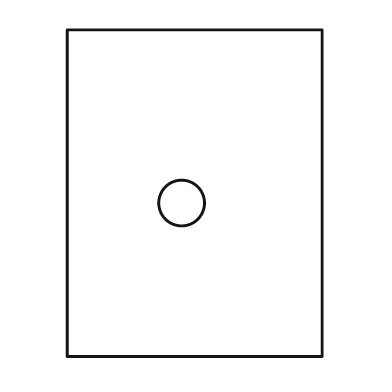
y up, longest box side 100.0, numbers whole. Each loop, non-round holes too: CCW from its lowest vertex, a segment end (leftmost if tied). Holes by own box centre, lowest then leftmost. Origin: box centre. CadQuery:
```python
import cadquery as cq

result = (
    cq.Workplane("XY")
    .moveTo(-39.0, -50.0)
    .lineTo(39.0, -50.0)
    .lineTo(39.0, 50.0)
    .lineTo(-39.0, 50.0)
    .close()
    .moveTo(-4.0, -3.0)
    .circle(7.0)
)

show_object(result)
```